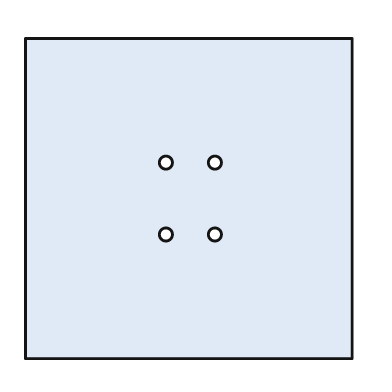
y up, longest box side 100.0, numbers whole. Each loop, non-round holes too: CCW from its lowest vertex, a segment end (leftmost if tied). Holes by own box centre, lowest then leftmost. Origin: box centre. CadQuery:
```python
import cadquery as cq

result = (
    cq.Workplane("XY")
    .moveTo(-50.0, -49.0)
    .lineTo(50.0, -49.0)
    .lineTo(50.0, 49.0)
    .lineTo(-50.0, 49.0)
    .close()
    .moveTo(-7.0, -11.0)
    .circle(2.0)
    .moveTo(8.0, -11.0)
    .circle(2.0)
    .moveTo(-7.0, 11.0)
    .circle(2.0)
    .moveTo(8.0, 11.0)
    .circle(2.0)
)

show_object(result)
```